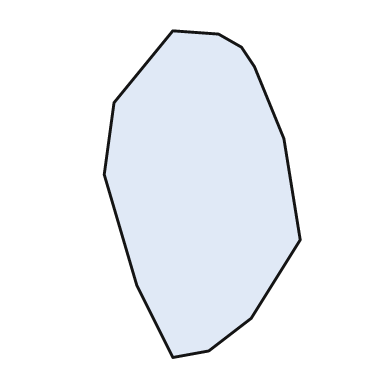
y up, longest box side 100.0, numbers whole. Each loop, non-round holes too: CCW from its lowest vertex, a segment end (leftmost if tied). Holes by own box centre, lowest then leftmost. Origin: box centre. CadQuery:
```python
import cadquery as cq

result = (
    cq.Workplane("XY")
    .moveTo(-9.0, -50.0)
    .lineTo(2.0, -48.0)
    .lineTo(15.0, -38.0)
    .lineTo(30.0, -14.0)
    .lineTo(25.0, 17.0)
    .lineTo(16.0, 39.0)
    .lineTo(12.0, 45.0)
    .lineTo(5.0, 49.0)
    .lineTo(-9.0, 50.0)
    .lineTo(-27.0, 28.0)
    .lineTo(-30.0, 6.0)
    .lineTo(-20.0, -28.0)
    .close()
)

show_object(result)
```